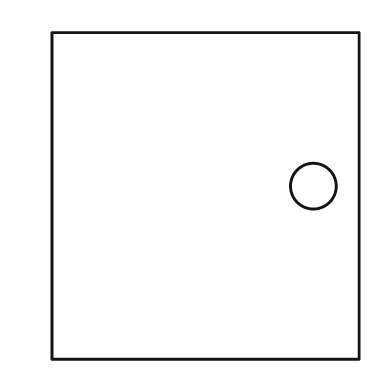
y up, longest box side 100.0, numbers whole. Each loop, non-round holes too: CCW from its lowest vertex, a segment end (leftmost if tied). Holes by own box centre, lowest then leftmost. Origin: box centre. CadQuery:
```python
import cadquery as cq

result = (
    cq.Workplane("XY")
    .moveTo(-47.0, -50.0)
    .lineTo(47.0, -50.0)
    .lineTo(47.0, 50.0)
    .lineTo(-47.0, 50.0)
    .close()
    .moveTo(33.0, 3.0)
    .circle(7.0)
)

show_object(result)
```